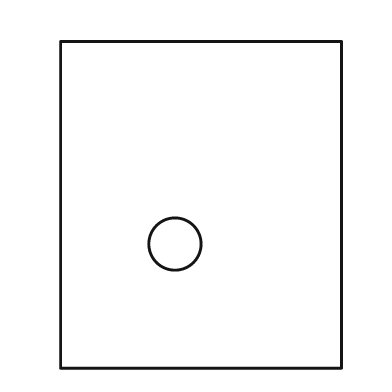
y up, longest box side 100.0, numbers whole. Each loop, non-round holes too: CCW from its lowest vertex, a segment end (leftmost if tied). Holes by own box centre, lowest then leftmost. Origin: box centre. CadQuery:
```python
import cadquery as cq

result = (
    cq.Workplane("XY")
    .moveTo(-43.0, -50.0)
    .lineTo(43.0, -50.0)
    .lineTo(43.0, 50.0)
    .lineTo(-43.0, 50.0)
    .close()
    .moveTo(-8.0, -12.0)
    .circle(8.0)
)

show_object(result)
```